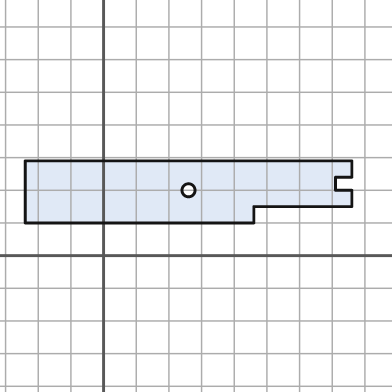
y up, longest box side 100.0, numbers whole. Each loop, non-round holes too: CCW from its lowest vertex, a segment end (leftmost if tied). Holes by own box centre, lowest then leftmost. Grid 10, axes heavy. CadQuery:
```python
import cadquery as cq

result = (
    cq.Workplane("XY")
    .moveTo(-24.0, 10.0)
    .lineTo(46.0, 10.0)
    .lineTo(46.0, 15.0)
    .lineTo(76.0, 15.0)
    .lineTo(76.0, 20.0)
    .lineTo(71.0, 20.0)
    .lineTo(71.0, 24.0)
    .lineTo(76.0, 24.0)
    .lineTo(76.0, 29.0)
    .lineTo(-24.0, 29.0)
    .close()
    .moveTo(26.0, 20.0)
    .circle(2.0)
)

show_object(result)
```